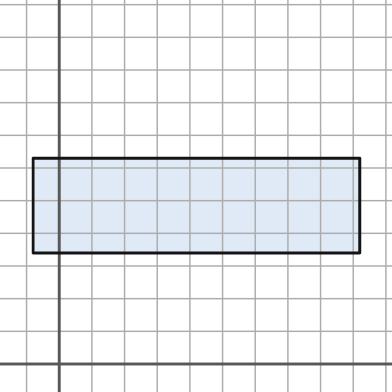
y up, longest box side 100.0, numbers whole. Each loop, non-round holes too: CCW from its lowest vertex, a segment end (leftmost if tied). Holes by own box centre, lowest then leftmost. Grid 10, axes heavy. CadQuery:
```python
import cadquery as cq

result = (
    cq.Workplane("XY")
    .moveTo(-8.0, 34.0)
    .lineTo(92.0, 34.0)
    .lineTo(92.0, 63.0)
    .lineTo(-8.0, 63.0)
    .close()
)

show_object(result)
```